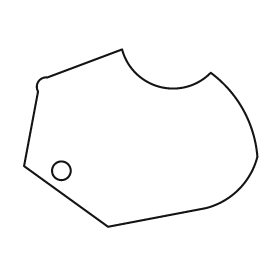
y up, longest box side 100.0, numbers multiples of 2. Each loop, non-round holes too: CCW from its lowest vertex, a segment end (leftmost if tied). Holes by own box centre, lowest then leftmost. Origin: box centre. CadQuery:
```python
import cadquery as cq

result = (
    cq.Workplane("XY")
    .moveTo(-14.0, -38.0)
    .lineTo(28.0, -30.0)
    .threePointArc((42.0, -22.0), (50.0, -8.0))
    .threePointArc((44.0, 12.0), (30.0, 28.0))
    .threePointArc((8.0, 22.0), (-8.0, 38.0))
    .lineTo(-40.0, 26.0)
    .threePointArc((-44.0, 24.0), (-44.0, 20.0))
    .lineTo(-50.0, -12.0)
    .close()
    .moveTo(-34.0, -14.0)
    .circle(4.0)
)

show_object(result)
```